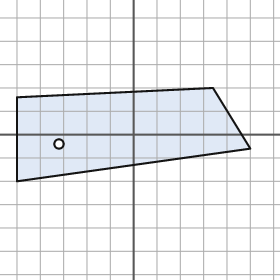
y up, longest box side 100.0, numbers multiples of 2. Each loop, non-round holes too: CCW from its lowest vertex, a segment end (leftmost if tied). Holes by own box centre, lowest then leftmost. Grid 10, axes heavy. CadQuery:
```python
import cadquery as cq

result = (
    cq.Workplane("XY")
    .moveTo(-50.0, -20.0)
    .lineTo(50.0, -6.0)
    .lineTo(34.0, 20.0)
    .lineTo(-50.0, 16.0)
    .close()
    .moveTo(-32.0, -4.0)
    .circle(2.0)
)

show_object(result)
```